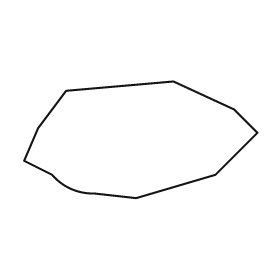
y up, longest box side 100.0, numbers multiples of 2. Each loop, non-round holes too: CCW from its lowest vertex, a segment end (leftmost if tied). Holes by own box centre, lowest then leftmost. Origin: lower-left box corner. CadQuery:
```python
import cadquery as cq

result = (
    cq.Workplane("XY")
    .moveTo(48.0, 0.0)
    .lineTo(82.0, 10.0)
    .lineTo(100.0, 28.0)
    .lineTo(90.0, 38.0)
    .lineTo(64.0, 50.0)
    .lineTo(18.0, 46.0)
    .lineTo(6.0, 30.0)
    .lineTo(0.0, 16.0)
    .lineTo(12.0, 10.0)
    .threePointArc((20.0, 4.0), (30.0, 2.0))
    .close()
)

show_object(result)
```